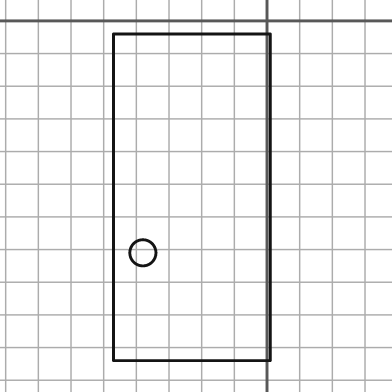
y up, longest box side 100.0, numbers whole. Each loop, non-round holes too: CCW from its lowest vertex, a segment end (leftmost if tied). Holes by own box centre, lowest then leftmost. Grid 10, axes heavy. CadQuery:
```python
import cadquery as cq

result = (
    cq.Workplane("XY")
    .moveTo(-47.0, -104.0)
    .lineTo(1.0, -104.0)
    .lineTo(1.0, -4.0)
    .lineTo(-47.0, -4.0)
    .close()
    .moveTo(-38.0, -71.0)
    .circle(4.0)
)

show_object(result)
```